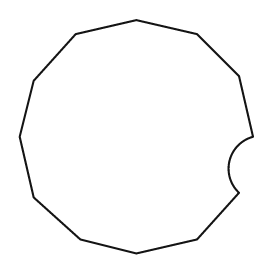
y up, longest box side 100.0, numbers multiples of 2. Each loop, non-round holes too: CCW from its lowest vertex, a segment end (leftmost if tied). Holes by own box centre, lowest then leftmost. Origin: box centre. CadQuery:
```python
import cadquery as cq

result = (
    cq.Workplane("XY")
    .moveTo(0.0, -50.0)
    .lineTo(26.0, -44.0)
    .lineTo(44.0, -24.0)
    .threePointArc((40.0, -10.0), (50.0, 0.0))
    .lineTo(44.0, 26.0)
    .lineTo(26.0, 44.0)
    .lineTo(0.0, 50.0)
    .lineTo(-26.0, 44.0)
    .lineTo(-44.0, 24.0)
    .lineTo(-50.0, 0.0)
    .lineTo(-44.0, -26.0)
    .lineTo(-24.0, -44.0)
    .close()
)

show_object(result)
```